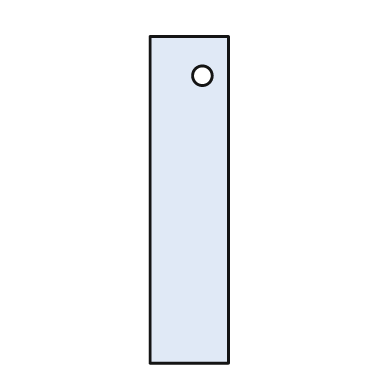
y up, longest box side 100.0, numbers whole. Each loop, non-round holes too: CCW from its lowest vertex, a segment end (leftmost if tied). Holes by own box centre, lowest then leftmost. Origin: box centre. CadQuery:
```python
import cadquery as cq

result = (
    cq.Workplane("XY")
    .moveTo(-12.0, -50.0)
    .lineTo(12.0, -50.0)
    .lineTo(12.0, 50.0)
    .lineTo(-12.0, 50.0)
    .close()
    .moveTo(4.0, 38.0)
    .circle(3.0)
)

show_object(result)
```